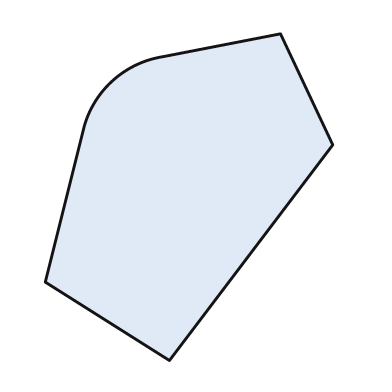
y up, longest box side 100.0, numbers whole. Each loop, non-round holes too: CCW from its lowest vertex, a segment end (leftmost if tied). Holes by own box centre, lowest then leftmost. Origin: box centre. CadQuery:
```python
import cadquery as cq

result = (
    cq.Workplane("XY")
    .moveTo(-6.0, -50.0)
    .lineTo(44.0, 16.0)
    .lineTo(28.0, 50.0)
    .lineTo(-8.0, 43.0)
    .threePointArc((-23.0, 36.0), (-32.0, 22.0))
    .lineTo(-44.0, -26.0)
    .close()
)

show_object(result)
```